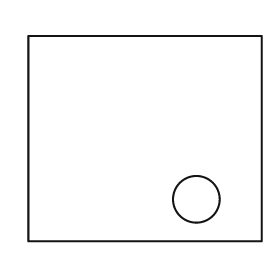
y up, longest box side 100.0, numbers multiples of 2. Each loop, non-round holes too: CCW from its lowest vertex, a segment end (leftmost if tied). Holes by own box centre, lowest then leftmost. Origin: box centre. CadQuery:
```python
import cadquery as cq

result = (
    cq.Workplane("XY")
    .moveTo(-50.0, -44.0)
    .lineTo(50.0, -44.0)
    .lineTo(50.0, 44.0)
    .lineTo(-50.0, 44.0)
    .close()
    .moveTo(22.0, -26.0)
    .circle(10.0)
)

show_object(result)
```